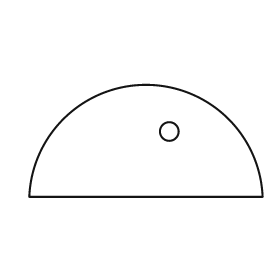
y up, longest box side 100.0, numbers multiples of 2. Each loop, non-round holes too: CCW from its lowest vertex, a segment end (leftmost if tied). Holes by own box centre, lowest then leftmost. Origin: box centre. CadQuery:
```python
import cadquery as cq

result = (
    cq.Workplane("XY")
    .moveTo(-50.0, -24.0)
    .lineTo(50.0, -24.0)
    .threePointArc((0.0, 24.0), (-50.0, -24.0))
    .close()
    .moveTo(10.0, 4.0)
    .circle(4.0)
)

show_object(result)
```